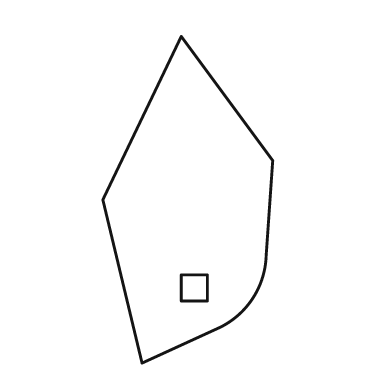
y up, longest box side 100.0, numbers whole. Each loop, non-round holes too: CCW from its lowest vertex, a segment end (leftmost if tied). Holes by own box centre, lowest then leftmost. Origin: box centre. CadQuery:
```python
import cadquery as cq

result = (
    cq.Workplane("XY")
    .moveTo(-14.0, -50.0)
    .lineTo(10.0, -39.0)
    .threePointArc((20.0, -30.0), (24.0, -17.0))
    .lineTo(26.0, 12.0)
    .lineTo(-2.0, 50.0)
    .lineTo(-26.0, 0.0)
    .close()
    .moveTo(-2.0, -31.0)
    .lineTo(6.0, -31.0)
    .lineTo(6.0, -23.0)
    .lineTo(-2.0, -23.0)
    .close()
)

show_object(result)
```